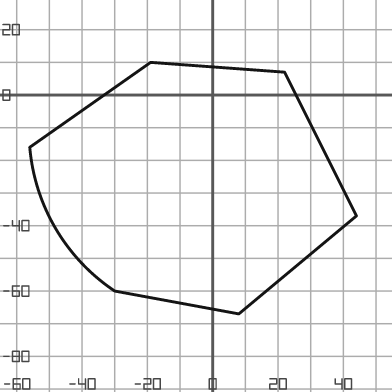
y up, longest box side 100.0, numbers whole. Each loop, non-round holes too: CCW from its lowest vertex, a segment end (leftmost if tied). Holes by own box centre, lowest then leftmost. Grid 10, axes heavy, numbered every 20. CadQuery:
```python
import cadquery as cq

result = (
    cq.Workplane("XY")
    .moveTo(8.0, -67.0)
    .lineTo(44.0, -37.0)
    .lineTo(22.0, 7.0)
    .lineTo(-19.0, 10.0)
    .lineTo(-56.0, -16.0)
    .threePointArc((-48.0, -41.0), (-30.0, -60.0))
    .close()
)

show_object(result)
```